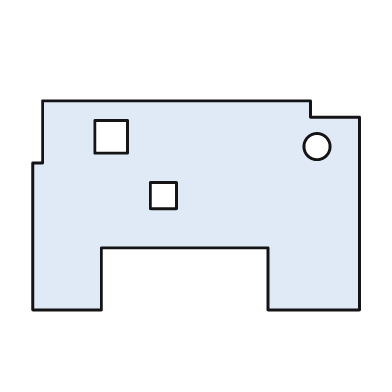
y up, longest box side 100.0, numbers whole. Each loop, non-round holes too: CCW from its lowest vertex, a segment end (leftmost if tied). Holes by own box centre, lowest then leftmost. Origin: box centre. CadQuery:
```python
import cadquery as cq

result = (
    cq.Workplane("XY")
    .moveTo(-50.0, -32.0)
    .lineTo(-29.0, -32.0)
    .lineTo(-29.0, -13.0)
    .lineTo(22.0, -13.0)
    .lineTo(22.0, -32.0)
    .lineTo(50.0, -32.0)
    .lineTo(50.0, 27.0)
    .lineTo(35.0, 27.0)
    .lineTo(35.0, 32.0)
    .lineTo(-47.0, 32.0)
    .lineTo(-47.0, 13.0)
    .lineTo(-50.0, 13.0)
    .close()
    .moveTo(-14.0, -1.0)
    .lineTo(-6.0, -1.0)
    .lineTo(-6.0, 7.0)
    .lineTo(-14.0, 7.0)
    .close()
    .moveTo(37.0, 18.0)
    .circle(4.0)
    .moveTo(-31.0, 16.0)
    .lineTo(-21.0, 16.0)
    .lineTo(-21.0, 26.0)
    .lineTo(-31.0, 26.0)
    .close()
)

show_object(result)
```